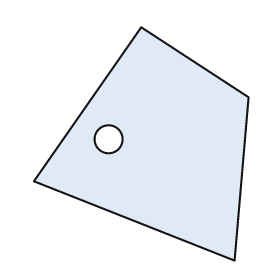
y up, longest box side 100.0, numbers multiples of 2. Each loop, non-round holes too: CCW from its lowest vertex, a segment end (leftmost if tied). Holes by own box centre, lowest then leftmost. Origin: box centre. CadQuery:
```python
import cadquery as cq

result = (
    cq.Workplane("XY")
    .moveTo(40.0, -50.0)
    .lineTo(46.0, 20.0)
    .lineTo(0.0, 50.0)
    .lineTo(-46.0, -16.0)
    .close()
    .moveTo(-14.0, 2.0)
    .circle(6.0)
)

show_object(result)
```